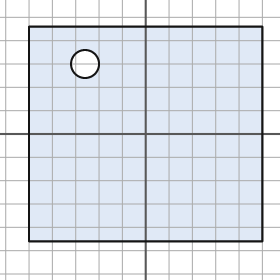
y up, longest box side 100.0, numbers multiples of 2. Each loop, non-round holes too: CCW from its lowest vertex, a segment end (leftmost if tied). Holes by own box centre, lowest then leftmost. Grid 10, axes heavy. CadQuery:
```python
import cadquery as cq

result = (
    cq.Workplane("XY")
    .moveTo(-50.0, -46.0)
    .lineTo(50.0, -46.0)
    .lineTo(50.0, 46.0)
    .lineTo(-50.0, 46.0)
    .close()
    .moveTo(-26.0, 30.0)
    .circle(6.0)
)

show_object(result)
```